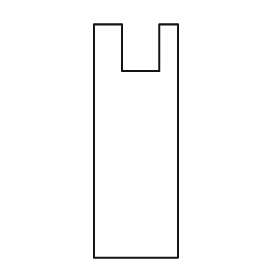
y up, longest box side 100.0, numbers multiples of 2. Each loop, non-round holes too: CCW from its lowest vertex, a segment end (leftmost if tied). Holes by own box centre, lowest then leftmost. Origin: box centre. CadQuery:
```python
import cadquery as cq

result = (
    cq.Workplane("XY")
    .moveTo(-18.0, -50.0)
    .lineTo(18.0, -50.0)
    .lineTo(18.0, 50.0)
    .lineTo(10.0, 50.0)
    .lineTo(10.0, 30.0)
    .lineTo(-6.0, 30.0)
    .lineTo(-6.0, 50.0)
    .lineTo(-18.0, 50.0)
    .close()
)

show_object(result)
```